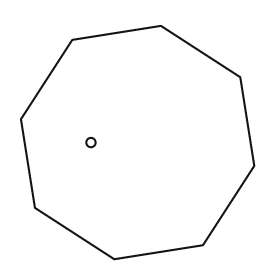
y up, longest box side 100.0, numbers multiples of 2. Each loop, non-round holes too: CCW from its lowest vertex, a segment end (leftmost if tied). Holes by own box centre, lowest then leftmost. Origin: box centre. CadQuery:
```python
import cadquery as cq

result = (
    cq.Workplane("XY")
    .moveTo(-10.0, -50.0)
    .lineTo(28.0, -44.0)
    .lineTo(50.0, -10.0)
    .lineTo(44.0, 28.0)
    .lineTo(10.0, 50.0)
    .lineTo(-28.0, 44.0)
    .lineTo(-50.0, 10.0)
    .lineTo(-44.0, -28.0)
    .close()
    .moveTo(-20.0, 0.0)
    .circle(2.0)
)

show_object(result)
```